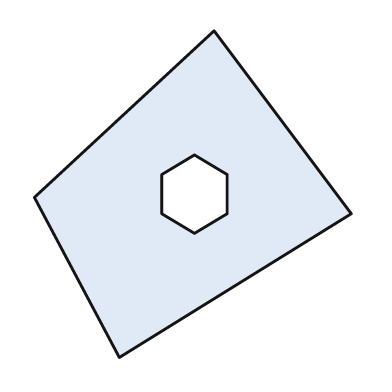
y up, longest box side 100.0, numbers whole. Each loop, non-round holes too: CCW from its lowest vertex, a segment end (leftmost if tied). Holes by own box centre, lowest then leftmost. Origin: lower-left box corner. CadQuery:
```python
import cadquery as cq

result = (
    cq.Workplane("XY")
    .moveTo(26.0, 0.0)
    .lineTo(97.0, 44.0)
    .lineTo(55.0, 100.0)
    .lineTo(0.0, 49.0)
    .close()
    .moveTo(49.0, 38.0)
    .lineTo(59.0, 44.0)
    .lineTo(59.0, 56.0)
    .lineTo(49.0, 62.0)
    .lineTo(39.0, 56.0)
    .lineTo(39.0, 44.0)
    .close()
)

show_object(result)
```